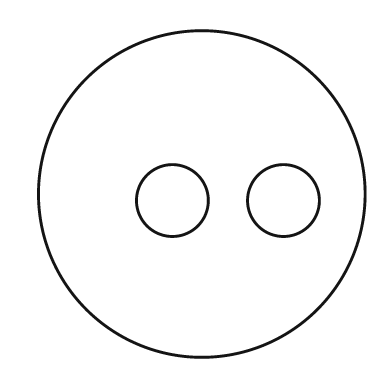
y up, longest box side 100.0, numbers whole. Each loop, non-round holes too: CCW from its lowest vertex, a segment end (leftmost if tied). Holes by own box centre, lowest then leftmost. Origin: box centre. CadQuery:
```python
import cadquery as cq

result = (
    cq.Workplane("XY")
    .moveTo(0.0, 0.0)
    .circle(50.0)
    .moveTo(-9.0, -2.0)
    .circle(11.0)
    .moveTo(25.0, -2.0)
    .circle(11.0)
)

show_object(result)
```